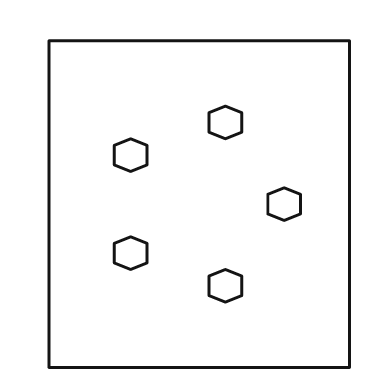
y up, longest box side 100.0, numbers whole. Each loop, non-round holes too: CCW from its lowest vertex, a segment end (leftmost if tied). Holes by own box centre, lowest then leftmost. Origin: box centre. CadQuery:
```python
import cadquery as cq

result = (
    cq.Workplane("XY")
    .moveTo(-46.0, -50.0)
    .lineTo(46.0, -50.0)
    .lineTo(46.0, 50.0)
    .lineTo(-46.0, 50.0)
    .close()
    .moveTo(8.0, -30.0)
    .lineTo(13.0, -28.0)
    .lineTo(13.0, -22.0)
    .lineTo(8.0, -20.0)
    .lineTo(3.0, -22.0)
    .lineTo(3.0, -28.0)
    .close()
    .moveTo(-21.0, -20.0)
    .lineTo(-16.0, -18.0)
    .lineTo(-16.0, -12.0)
    .lineTo(-21.0, -10.0)
    .lineTo(-26.0, -12.0)
    .lineTo(-26.0, -18.0)
    .close()
    .moveTo(26.0, -5.0)
    .lineTo(31.0, -3.0)
    .lineTo(31.0, 3.0)
    .lineTo(26.0, 5.0)
    .lineTo(21.0, 3.0)
    .lineTo(21.0, -3.0)
    .close()
    .moveTo(-21.0, 10.0)
    .lineTo(-16.0, 12.0)
    .lineTo(-16.0, 18.0)
    .lineTo(-21.0, 20.0)
    .lineTo(-26.0, 18.0)
    .lineTo(-26.0, 12.0)
    .close()
    .moveTo(8.0, 20.0)
    .lineTo(13.0, 22.0)
    .lineTo(13.0, 28.0)
    .lineTo(8.0, 30.0)
    .lineTo(3.0, 28.0)
    .lineTo(3.0, 22.0)
    .close()
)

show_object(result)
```